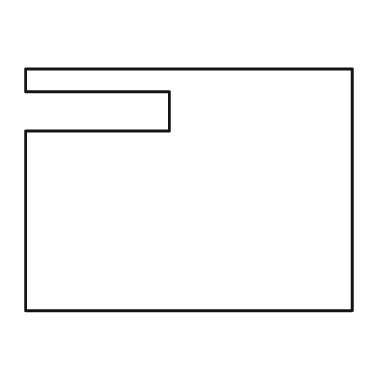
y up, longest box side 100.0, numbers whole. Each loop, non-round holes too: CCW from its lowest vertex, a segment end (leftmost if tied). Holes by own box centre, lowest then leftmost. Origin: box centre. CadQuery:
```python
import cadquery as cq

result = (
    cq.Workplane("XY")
    .moveTo(-50.0, -37.0)
    .lineTo(50.0, -37.0)
    .lineTo(50.0, 37.0)
    .lineTo(-50.0, 37.0)
    .lineTo(-50.0, 30.0)
    .lineTo(-6.0, 30.0)
    .lineTo(-6.0, 18.0)
    .lineTo(-50.0, 18.0)
    .close()
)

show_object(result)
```